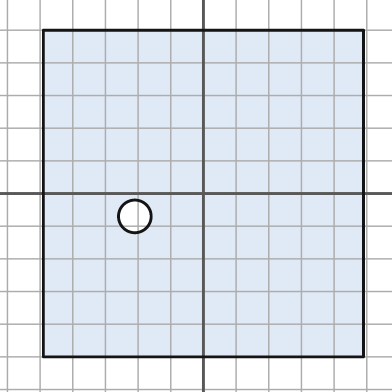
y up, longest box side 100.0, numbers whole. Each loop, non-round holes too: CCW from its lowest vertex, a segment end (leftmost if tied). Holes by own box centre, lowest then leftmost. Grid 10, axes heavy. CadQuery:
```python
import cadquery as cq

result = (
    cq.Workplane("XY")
    .moveTo(-49.0, -50.0)
    .lineTo(49.0, -50.0)
    .lineTo(49.0, 50.0)
    .lineTo(-49.0, 50.0)
    .close()
    .moveTo(-21.0, -7.0)
    .circle(5.0)
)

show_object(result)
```